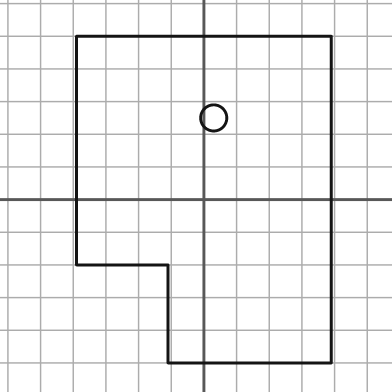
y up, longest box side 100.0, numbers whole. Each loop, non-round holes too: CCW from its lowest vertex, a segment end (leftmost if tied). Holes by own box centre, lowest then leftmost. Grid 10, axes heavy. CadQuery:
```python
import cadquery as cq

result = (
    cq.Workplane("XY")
    .moveTo(-11.0, -50.0)
    .lineTo(39.0, -50.0)
    .lineTo(39.0, 50.0)
    .lineTo(-39.0, 50.0)
    .lineTo(-39.0, -20.0)
    .lineTo(-11.0, -20.0)
    .close()
    .moveTo(3.0, 25.0)
    .circle(4.0)
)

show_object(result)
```